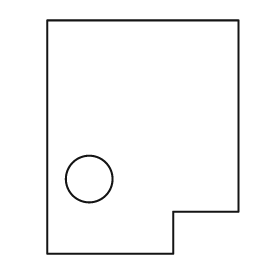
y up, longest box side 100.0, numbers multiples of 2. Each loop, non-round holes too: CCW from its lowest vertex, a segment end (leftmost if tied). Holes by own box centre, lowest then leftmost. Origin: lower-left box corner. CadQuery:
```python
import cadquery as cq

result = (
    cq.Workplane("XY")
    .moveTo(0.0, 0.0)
    .lineTo(54.0, 0.0)
    .lineTo(54.0, 18.0)
    .lineTo(82.0, 18.0)
    .lineTo(82.0, 100.0)
    .lineTo(0.0, 100.0)
    .close()
    .moveTo(18.0, 32.0)
    .circle(10.0)
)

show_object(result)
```